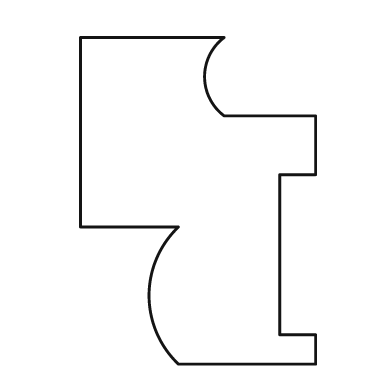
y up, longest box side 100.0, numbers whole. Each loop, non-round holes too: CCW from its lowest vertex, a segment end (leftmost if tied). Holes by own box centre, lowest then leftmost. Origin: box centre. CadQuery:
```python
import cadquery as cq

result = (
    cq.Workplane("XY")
    .moveTo(-6.0, -50.0)
    .lineTo(36.0, -50.0)
    .lineTo(36.0, -41.0)
    .lineTo(25.0, -41.0)
    .lineTo(25.0, 8.0)
    .lineTo(36.0, 8.0)
    .lineTo(36.0, 26.0)
    .lineTo(8.0, 26.0)
    .threePointArc((2.0, 38.0), (8.0, 50.0))
    .lineTo(-36.0, 50.0)
    .lineTo(-36.0, -8.0)
    .lineTo(-6.0, -8.0)
    .threePointArc((-15.0, -29.0), (-6.0, -50.0))
    .close()
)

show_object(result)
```